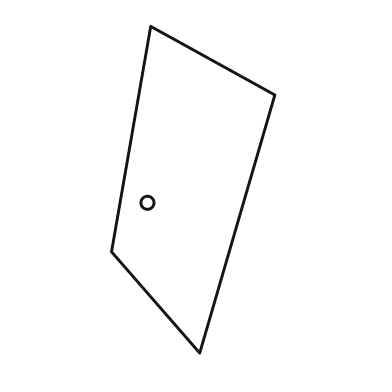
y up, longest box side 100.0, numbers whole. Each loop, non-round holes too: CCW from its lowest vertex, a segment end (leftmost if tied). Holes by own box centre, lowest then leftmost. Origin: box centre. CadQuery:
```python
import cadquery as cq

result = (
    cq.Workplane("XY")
    .moveTo(2.0, -50.0)
    .lineTo(25.0, 29.0)
    .lineTo(-13.0, 50.0)
    .lineTo(-25.0, -19.0)
    .close()
    .moveTo(-14.0, -4.0)
    .circle(2.0)
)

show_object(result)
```